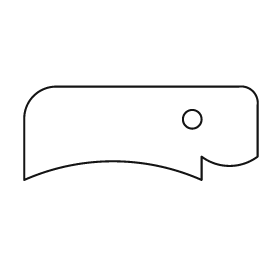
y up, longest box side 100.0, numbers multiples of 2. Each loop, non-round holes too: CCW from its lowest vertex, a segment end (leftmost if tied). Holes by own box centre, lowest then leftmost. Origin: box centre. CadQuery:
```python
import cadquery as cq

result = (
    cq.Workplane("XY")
    .moveTo(-50.0, -20.0)
    .threePointArc((-12.0, -12.0), (26.0, -20.0))
    .lineTo(26.0, -10.0)
    .threePointArc((38.0, -14.0), (50.0, -10.0))
    .lineTo(50.0, 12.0)
    .threePointArc((48.0, 18.0), (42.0, 20.0))
    .lineTo(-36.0, 20.0)
    .threePointArc((-46.0, 16.0), (-50.0, 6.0))
    .close()
    .moveTo(22.0, 6.0)
    .circle(4.0)
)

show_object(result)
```